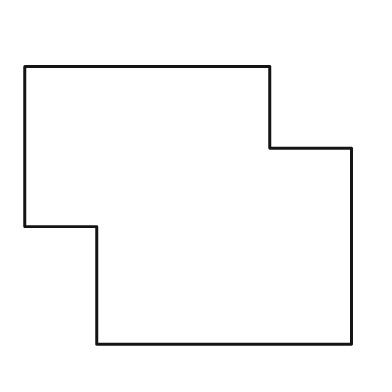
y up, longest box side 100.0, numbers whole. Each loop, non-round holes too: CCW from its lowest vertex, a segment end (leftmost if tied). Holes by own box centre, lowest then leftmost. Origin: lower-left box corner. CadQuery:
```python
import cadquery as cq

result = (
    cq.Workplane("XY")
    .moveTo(22.0, 0.0)
    .lineTo(100.0, 0.0)
    .lineTo(100.0, 60.0)
    .lineTo(75.0, 60.0)
    .lineTo(75.0, 85.0)
    .lineTo(0.0, 85.0)
    .lineTo(0.0, 36.0)
    .lineTo(22.0, 36.0)
    .close()
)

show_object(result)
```